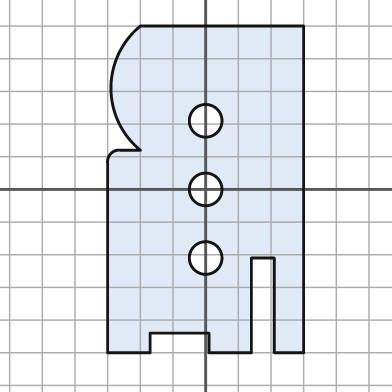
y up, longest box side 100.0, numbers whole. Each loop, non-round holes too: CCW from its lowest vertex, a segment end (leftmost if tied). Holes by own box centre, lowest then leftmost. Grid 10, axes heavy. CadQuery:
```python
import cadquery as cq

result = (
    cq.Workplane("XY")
    .moveTo(-30.0, -50.0)
    .lineTo(-17.0, -50.0)
    .lineTo(-17.0, -44.0)
    .lineTo(1.0, -44.0)
    .lineTo(1.0, -50.0)
    .lineTo(14.0, -50.0)
    .lineTo(14.0, -21.0)
    .lineTo(21.0, -21.0)
    .lineTo(21.0, -50.0)
    .lineTo(30.0, -50.0)
    .lineTo(30.0, 50.0)
    .lineTo(-20.0, 50.0)
    .threePointArc((-29.0, 31.0), (-20.0, 12.0))
    .lineTo(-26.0, 12.0)
    .threePointArc((-29.0, 11.0), (-30.0, 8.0))
    .close()
    .moveTo(0.0, -21.0)
    .circle(5.0)
    .moveTo(0.0, 0.0)
    .circle(5.0)
    .moveTo(0.0, 21.0)
    .circle(5.0)
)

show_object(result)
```